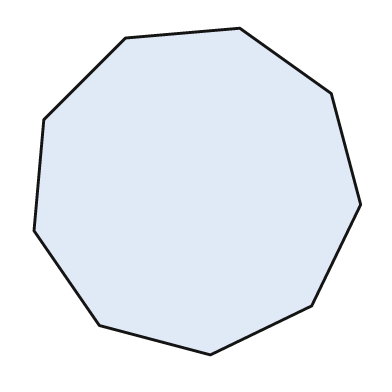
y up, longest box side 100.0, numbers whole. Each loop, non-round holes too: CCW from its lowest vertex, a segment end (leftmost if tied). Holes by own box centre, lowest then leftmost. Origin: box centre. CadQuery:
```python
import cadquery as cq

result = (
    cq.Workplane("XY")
    .moveTo(4.0, -50.0)
    .lineTo(35.0, -35.0)
    .lineTo(50.0, -4.0)
    .lineTo(41.0, 30.0)
    .lineTo(13.0, 50.0)
    .lineTo(-22.0, 47.0)
    .lineTo(-47.0, 22.0)
    .lineTo(-50.0, -12.0)
    .lineTo(-30.0, -41.0)
    .close()
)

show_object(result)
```